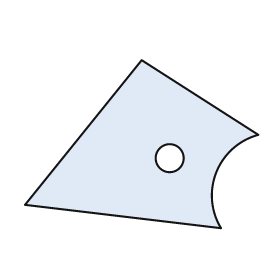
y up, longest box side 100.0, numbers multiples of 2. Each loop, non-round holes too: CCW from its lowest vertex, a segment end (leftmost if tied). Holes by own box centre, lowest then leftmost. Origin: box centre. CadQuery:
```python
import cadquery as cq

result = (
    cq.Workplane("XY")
    .moveTo(34.0, -36.0)
    .threePointArc((32.0, -12.0), (50.0, 4.0))
    .lineTo(0.0, 36.0)
    .lineTo(-50.0, -26.0)
    .close()
    .moveTo(12.0, -6.0)
    .circle(6.0)
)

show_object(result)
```